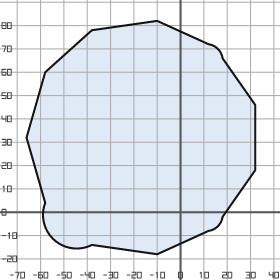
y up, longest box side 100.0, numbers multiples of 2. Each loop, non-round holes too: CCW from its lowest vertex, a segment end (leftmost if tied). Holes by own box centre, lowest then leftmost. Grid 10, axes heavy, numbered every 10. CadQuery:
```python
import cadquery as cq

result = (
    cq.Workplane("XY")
    .moveTo(-10.0, -18.0)
    .lineTo(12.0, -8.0)
    .threePointArc((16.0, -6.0), (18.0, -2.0))
    .lineTo(32.0, 18.0)
    .lineTo(32.0, 46.0)
    .lineTo(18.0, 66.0)
    .threePointArc((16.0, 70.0), (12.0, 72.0))
    .lineTo(-10.0, 82.0)
    .lineTo(-38.0, 78.0)
    .lineTo(-58.0, 60.0)
    .lineTo(-66.0, 32.0)
    .lineTo(-58.0, 4.0)
    .threePointArc((-54.0, -12.0), (-38.0, -14.0))
    .close()
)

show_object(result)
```